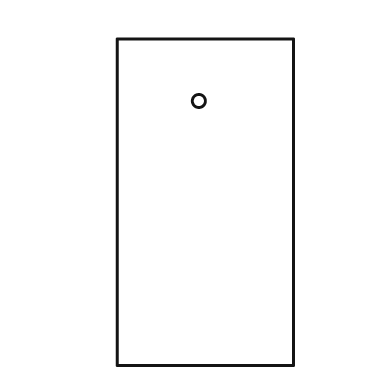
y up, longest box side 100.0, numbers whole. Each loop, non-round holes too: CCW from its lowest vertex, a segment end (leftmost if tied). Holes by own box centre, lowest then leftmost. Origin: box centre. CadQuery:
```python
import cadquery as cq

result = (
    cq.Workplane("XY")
    .moveTo(-27.0, -50.0)
    .lineTo(27.0, -50.0)
    .lineTo(27.0, 50.0)
    .lineTo(-27.0, 50.0)
    .close()
    .moveTo(-2.0, 31.0)
    .circle(2.0)
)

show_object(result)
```